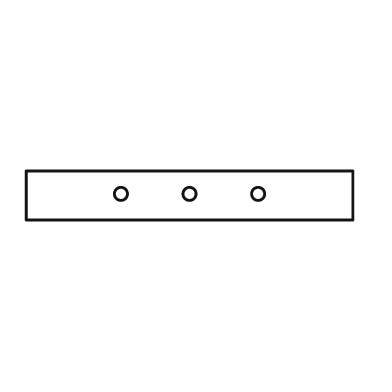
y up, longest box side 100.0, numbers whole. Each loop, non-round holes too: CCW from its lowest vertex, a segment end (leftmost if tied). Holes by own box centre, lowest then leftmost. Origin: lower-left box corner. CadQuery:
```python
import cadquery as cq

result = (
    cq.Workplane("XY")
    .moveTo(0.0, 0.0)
    .lineTo(100.0, 0.0)
    .lineTo(100.0, 15.0)
    .lineTo(0.0, 15.0)
    .close()
    .moveTo(29.0, 8.0)
    .circle(2.0)
    .moveTo(50.0, 8.0)
    .circle(2.0)
    .moveTo(71.0, 8.0)
    .circle(2.0)
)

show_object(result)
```